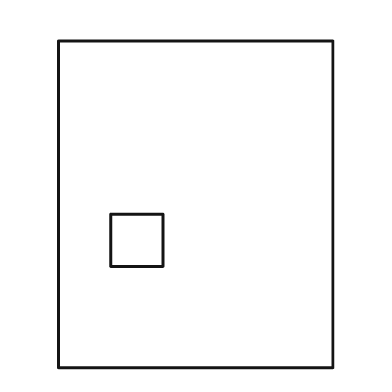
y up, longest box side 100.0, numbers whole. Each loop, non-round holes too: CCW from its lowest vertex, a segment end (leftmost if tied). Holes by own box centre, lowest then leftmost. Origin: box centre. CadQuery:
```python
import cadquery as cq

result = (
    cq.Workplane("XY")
    .moveTo(-42.0, -50.0)
    .lineTo(42.0, -50.0)
    .lineTo(42.0, 50.0)
    .lineTo(-42.0, 50.0)
    .close()
    .moveTo(-26.0, -19.0)
    .lineTo(-10.0, -19.0)
    .lineTo(-10.0, -3.0)
    .lineTo(-26.0, -3.0)
    .close()
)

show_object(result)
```